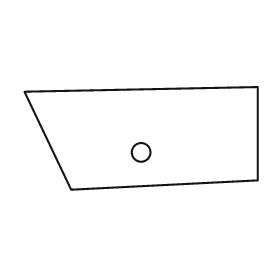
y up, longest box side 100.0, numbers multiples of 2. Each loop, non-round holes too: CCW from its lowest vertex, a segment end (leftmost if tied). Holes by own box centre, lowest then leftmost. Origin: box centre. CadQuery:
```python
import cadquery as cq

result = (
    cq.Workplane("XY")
    .moveTo(-30.0, -22.0)
    .lineTo(50.0, -18.0)
    .lineTo(50.0, 22.0)
    .lineTo(-50.0, 20.0)
    .close()
    .moveTo(0.0, -6.0)
    .circle(4.0)
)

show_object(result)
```